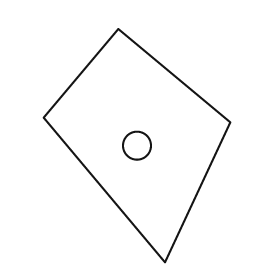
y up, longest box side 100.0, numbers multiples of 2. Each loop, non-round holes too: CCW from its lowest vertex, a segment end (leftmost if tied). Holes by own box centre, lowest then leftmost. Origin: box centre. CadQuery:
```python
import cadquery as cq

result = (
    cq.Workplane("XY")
    .moveTo(12.0, -50.0)
    .lineTo(40.0, 10.0)
    .lineTo(-8.0, 50.0)
    .lineTo(-40.0, 12.0)
    .close()
    .moveTo(0.0, 0.0)
    .circle(6.0)
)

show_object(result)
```